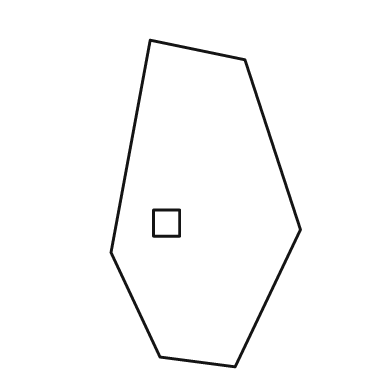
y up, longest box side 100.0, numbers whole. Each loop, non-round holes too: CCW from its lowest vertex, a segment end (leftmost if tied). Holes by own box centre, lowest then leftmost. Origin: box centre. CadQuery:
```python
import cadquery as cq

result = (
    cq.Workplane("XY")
    .moveTo(9.0, -50.0)
    .lineTo(29.0, -8.0)
    .lineTo(12.0, 44.0)
    .lineTo(-17.0, 50.0)
    .lineTo(-29.0, -15.0)
    .lineTo(-14.0, -47.0)
    .close()
    .moveTo(-16.0, -10.0)
    .lineTo(-8.0, -10.0)
    .lineTo(-8.0, -2.0)
    .lineTo(-16.0, -2.0)
    .close()
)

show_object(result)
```